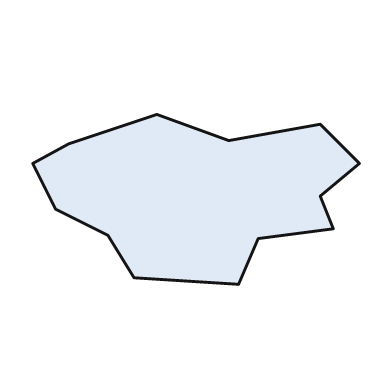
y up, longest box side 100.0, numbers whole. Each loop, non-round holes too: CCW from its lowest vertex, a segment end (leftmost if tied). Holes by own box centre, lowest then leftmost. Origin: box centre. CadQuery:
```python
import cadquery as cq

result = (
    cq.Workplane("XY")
    .moveTo(13.0, -26.0)
    .lineTo(19.0, -12.0)
    .lineTo(42.0, -9.0)
    .lineTo(38.0, 1.0)
    .lineTo(50.0, 11.0)
    .lineTo(38.0, 23.0)
    .lineTo(10.0, 18.0)
    .lineTo(-12.0, 26.0)
    .lineTo(-39.0, 17.0)
    .lineTo(-50.0, 11.0)
    .lineTo(-43.0, -3.0)
    .lineTo(-27.0, -11.0)
    .lineTo(-19.0, -24.0)
    .close()
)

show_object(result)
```